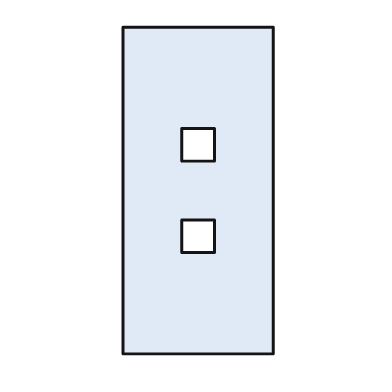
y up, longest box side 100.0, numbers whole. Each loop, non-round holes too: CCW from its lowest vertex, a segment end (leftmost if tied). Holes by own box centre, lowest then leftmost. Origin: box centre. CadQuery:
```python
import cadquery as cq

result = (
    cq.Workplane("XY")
    .moveTo(-23.0, -50.0)
    .lineTo(23.0, -50.0)
    .lineTo(23.0, 50.0)
    .lineTo(-23.0, 50.0)
    .close()
    .moveTo(-5.0, -19.0)
    .lineTo(5.0, -19.0)
    .lineTo(5.0, -9.0)
    .lineTo(-5.0, -9.0)
    .close()
    .moveTo(-5.0, 9.0)
    .lineTo(5.0, 9.0)
    .lineTo(5.0, 19.0)
    .lineTo(-5.0, 19.0)
    .close()
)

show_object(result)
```